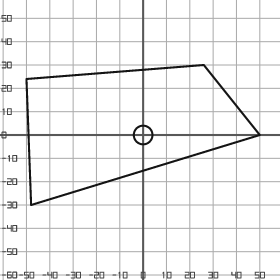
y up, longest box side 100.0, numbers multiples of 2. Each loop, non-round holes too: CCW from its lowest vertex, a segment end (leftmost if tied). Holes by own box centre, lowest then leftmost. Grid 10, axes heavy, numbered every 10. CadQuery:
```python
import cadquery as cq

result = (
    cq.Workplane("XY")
    .moveTo(-48.0, -30.0)
    .lineTo(50.0, 0.0)
    .lineTo(26.0, 30.0)
    .lineTo(-50.0, 24.0)
    .close()
    .moveTo(0.0, 0.0)
    .circle(4.0)
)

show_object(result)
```